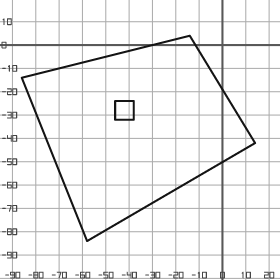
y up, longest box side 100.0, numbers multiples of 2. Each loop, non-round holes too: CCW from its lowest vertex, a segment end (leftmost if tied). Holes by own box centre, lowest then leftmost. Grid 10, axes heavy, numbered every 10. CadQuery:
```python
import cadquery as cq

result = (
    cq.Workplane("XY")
    .moveTo(-58.0, -84.0)
    .lineTo(14.0, -42.0)
    .lineTo(-14.0, 4.0)
    .lineTo(-86.0, -14.0)
    .close()
    .moveTo(-46.0, -32.0)
    .lineTo(-38.0, -32.0)
    .lineTo(-38.0, -24.0)
    .lineTo(-46.0, -24.0)
    .close()
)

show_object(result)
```